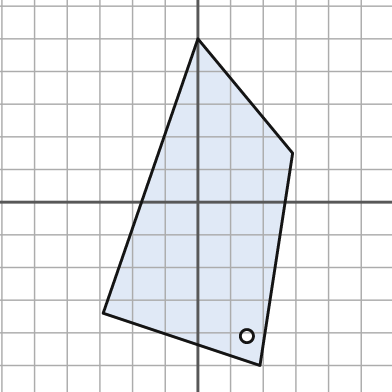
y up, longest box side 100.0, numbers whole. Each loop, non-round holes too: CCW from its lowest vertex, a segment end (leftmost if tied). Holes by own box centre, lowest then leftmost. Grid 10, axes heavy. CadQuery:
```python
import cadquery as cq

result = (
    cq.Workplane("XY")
    .moveTo(19.0, -50.0)
    .lineTo(29.0, 15.0)
    .lineTo(0.0, 50.0)
    .lineTo(-29.0, -34.0)
    .close()
    .moveTo(15.0, -41.0)
    .circle(2.0)
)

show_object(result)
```